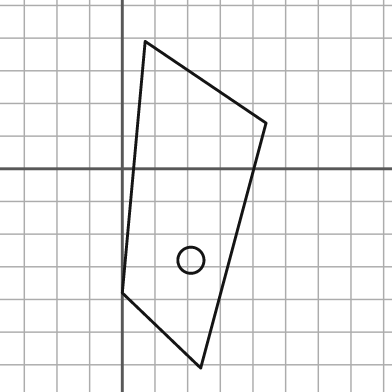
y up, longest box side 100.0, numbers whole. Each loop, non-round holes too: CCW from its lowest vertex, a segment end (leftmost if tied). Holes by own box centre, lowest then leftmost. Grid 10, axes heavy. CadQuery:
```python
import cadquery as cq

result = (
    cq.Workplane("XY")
    .moveTo(24.0, -61.0)
    .lineTo(44.0, 14.0)
    .lineTo(7.0, 39.0)
    .lineTo(0.0, -38.0)
    .close()
    .moveTo(21.0, -28.0)
    .circle(4.0)
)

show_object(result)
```